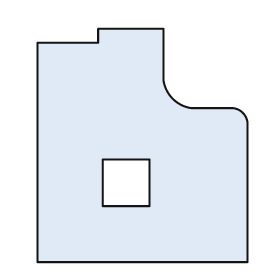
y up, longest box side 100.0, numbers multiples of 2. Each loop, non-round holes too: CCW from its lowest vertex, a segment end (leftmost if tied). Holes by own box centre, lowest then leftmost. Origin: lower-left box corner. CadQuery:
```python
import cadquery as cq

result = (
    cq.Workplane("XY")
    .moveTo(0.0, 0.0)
    .lineTo(90.0, 0.0)
    .lineTo(90.0, 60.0)
    .threePointArc((88.0, 64.0), (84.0, 66.0))
    .lineTo(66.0, 66.0)
    .threePointArc((58.0, 70.0), (54.0, 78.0))
    .lineTo(54.0, 100.0)
    .lineTo(26.0, 100.0)
    .lineTo(26.0, 94.0)
    .lineTo(0.0, 94.0)
    .close()
    .moveTo(28.0, 24.0)
    .lineTo(48.0, 24.0)
    .lineTo(48.0, 44.0)
    .lineTo(28.0, 44.0)
    .close()
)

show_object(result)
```